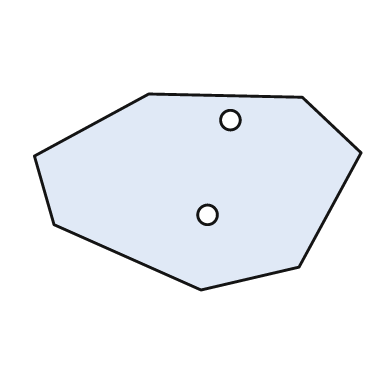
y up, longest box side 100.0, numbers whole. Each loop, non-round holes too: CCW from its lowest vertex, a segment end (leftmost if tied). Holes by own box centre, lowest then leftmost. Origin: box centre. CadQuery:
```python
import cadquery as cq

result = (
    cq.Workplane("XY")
    .moveTo(1.0, -30.0)
    .lineTo(31.0, -23.0)
    .lineTo(50.0, 12.0)
    .lineTo(32.0, 29.0)
    .lineTo(-15.0, 30.0)
    .lineTo(-50.0, 11.0)
    .lineTo(-44.0, -10.0)
    .close()
    .moveTo(3.0, -7.0)
    .circle(3.0)
    .moveTo(10.0, 22.0)
    .circle(3.0)
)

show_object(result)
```